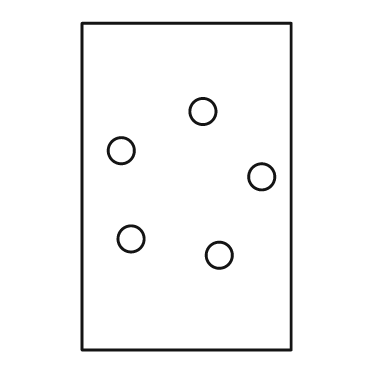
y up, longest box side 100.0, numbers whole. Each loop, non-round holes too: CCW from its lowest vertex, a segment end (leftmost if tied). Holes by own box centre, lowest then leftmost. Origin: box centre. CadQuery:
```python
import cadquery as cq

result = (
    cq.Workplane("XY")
    .moveTo(-32.0, -50.0)
    .lineTo(32.0, -50.0)
    .lineTo(32.0, 50.0)
    .lineTo(-32.0, 50.0)
    .close()
    .moveTo(10.0, -21.0)
    .circle(4.0)
    .moveTo(-17.0, -16.0)
    .circle(4.0)
    .moveTo(23.0, 3.0)
    .circle(4.0)
    .moveTo(-20.0, 11.0)
    .circle(4.0)
    .moveTo(5.0, 23.0)
    .circle(4.0)
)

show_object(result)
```